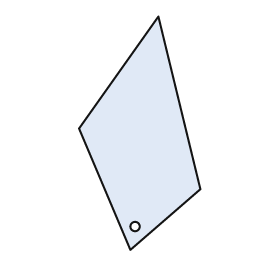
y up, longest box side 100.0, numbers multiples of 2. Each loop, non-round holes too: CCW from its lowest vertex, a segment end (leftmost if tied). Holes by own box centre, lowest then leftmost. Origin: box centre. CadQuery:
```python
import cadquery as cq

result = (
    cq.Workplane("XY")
    .moveTo(-4.0, -50.0)
    .lineTo(26.0, -24.0)
    .lineTo(8.0, 50.0)
    .lineTo(-26.0, 2.0)
    .close()
    .moveTo(-2.0, -40.0)
    .circle(2.0)
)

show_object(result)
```